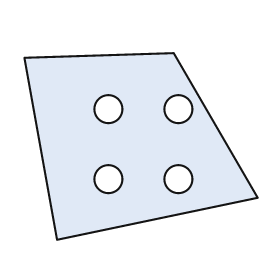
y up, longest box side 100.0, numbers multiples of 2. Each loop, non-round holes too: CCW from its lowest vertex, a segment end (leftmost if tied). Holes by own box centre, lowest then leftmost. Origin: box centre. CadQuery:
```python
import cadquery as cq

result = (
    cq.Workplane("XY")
    .moveTo(-36.0, -40.0)
    .lineTo(50.0, -22.0)
    .lineTo(14.0, 40.0)
    .lineTo(-50.0, 38.0)
    .close()
    .moveTo(-14.0, -14.0)
    .circle(6.0)
    .moveTo(16.0, -14.0)
    .circle(6.0)
    .moveTo(-14.0, 16.0)
    .circle(6.0)
    .moveTo(16.0, 16.0)
    .circle(6.0)
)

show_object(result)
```